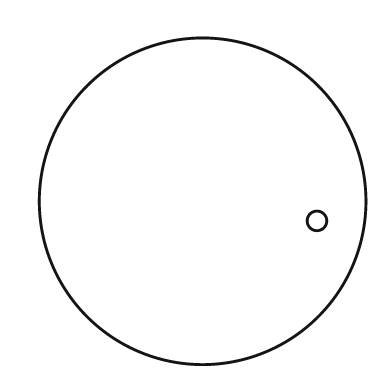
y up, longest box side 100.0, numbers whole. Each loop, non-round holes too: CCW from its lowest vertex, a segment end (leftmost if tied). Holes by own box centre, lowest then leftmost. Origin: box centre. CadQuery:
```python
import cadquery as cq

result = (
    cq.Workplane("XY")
    .moveTo(0.0, 0.0)
    .circle(50.0)
    .moveTo(35.0, -6.0)
    .circle(3.0)
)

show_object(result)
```